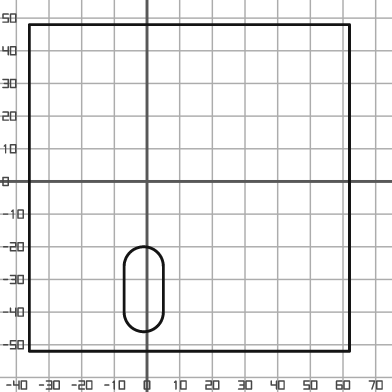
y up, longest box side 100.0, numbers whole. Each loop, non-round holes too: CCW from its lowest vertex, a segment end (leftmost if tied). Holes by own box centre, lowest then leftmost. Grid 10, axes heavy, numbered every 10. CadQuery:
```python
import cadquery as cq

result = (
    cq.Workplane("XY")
    .moveTo(-36.0, -52.0)
    .lineTo(62.0, -52.0)
    .lineTo(62.0, 48.0)
    .lineTo(-36.0, 48.0)
    .close()
    .moveTo(-7.0, -40.0)
    .threePointArc((-1.0, -46.0), (5.0, -40.0))
    .lineTo(5.0, -26.0)
    .threePointArc((-1.0, -20.0), (-7.0, -26.0))
    .close()
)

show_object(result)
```